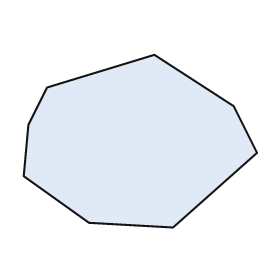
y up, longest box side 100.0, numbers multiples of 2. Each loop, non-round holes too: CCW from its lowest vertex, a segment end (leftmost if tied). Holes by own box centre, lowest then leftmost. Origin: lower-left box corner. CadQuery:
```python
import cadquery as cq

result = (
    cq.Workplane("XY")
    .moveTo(64.0, 0.0)
    .lineTo(100.0, 32.0)
    .lineTo(90.0, 52.0)
    .lineTo(56.0, 74.0)
    .lineTo(10.0, 60.0)
    .lineTo(2.0, 44.0)
    .lineTo(0.0, 22.0)
    .lineTo(28.0, 2.0)
    .close()
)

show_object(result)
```